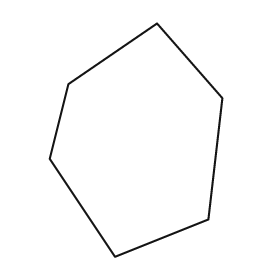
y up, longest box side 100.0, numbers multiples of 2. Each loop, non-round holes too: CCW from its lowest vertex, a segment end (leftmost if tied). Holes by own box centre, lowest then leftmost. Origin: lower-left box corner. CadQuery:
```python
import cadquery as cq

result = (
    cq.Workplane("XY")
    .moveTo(28.0, 0.0)
    .lineTo(68.0, 16.0)
    .lineTo(74.0, 68.0)
    .lineTo(46.0, 100.0)
    .lineTo(8.0, 74.0)
    .lineTo(0.0, 42.0)
    .close()
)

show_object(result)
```